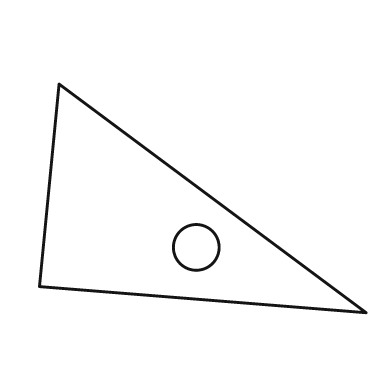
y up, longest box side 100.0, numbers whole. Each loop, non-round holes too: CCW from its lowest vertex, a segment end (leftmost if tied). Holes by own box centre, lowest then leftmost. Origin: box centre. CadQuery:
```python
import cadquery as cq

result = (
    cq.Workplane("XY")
    .moveTo(50.0, -35.0)
    .lineTo(-44.0, 35.0)
    .lineTo(-50.0, -27.0)
    .close()
    .moveTo(-2.0, -15.0)
    .circle(7.0)
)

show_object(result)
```